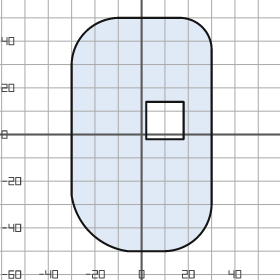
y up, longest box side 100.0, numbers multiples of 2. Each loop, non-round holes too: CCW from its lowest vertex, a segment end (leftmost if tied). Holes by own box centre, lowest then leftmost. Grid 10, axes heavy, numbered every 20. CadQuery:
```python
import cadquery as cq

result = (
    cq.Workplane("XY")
    .moveTo(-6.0, -50.0)
    .lineTo(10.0, -50.0)
    .threePointArc((24.0, -44.0), (30.0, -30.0))
    .lineTo(30.0, 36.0)
    .threePointArc((26.0, 46.0), (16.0, 50.0))
    .lineTo(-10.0, 50.0)
    .threePointArc((-24.0, 44.0), (-30.0, 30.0))
    .lineTo(-30.0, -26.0)
    .threePointArc((-22.0, -42.0), (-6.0, -50.0))
    .close()
    .moveTo(2.0, -2.0)
    .lineTo(18.0, -2.0)
    .lineTo(18.0, 14.0)
    .lineTo(2.0, 14.0)
    .close()
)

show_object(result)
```